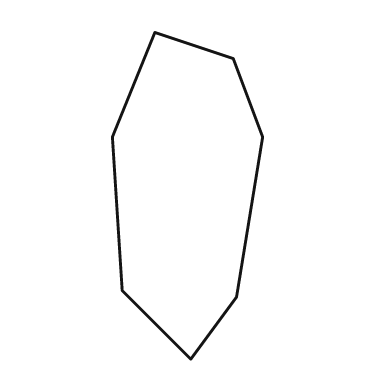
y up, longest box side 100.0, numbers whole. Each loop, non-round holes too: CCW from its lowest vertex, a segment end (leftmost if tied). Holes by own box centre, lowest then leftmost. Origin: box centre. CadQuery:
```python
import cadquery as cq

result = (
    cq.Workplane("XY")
    .moveTo(1.0, -50.0)
    .lineTo(15.0, -31.0)
    .lineTo(23.0, 18.0)
    .lineTo(14.0, 42.0)
    .lineTo(-10.0, 50.0)
    .lineTo(-23.0, 18.0)
    .lineTo(-20.0, -29.0)
    .close()
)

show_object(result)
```